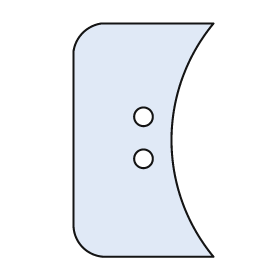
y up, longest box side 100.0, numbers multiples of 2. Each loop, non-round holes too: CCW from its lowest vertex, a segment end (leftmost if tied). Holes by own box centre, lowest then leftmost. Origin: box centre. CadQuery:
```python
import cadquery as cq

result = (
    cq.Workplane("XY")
    .moveTo(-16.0, -50.0)
    .lineTo(30.0, -50.0)
    .threePointArc((12.0, 0.0), (30.0, 50.0))
    .lineTo(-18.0, 50.0)
    .threePointArc((-26.0, 46.0), (-30.0, 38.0))
    .lineTo(-30.0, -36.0)
    .threePointArc((-26.0, -46.0), (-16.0, -50.0))
    .close()
    .moveTo(0.0, -8.0)
    .circle(4.0)
    .moveTo(0.0, 10.0)
    .circle(4.0)
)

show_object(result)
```